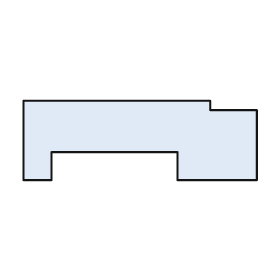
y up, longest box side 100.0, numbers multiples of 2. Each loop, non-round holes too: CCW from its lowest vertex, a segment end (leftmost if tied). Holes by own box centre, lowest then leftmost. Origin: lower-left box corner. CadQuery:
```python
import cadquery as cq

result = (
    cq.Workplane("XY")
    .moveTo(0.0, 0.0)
    .lineTo(12.0, 0.0)
    .lineTo(12.0, 12.0)
    .lineTo(66.0, 12.0)
    .lineTo(66.0, 0.0)
    .lineTo(100.0, 0.0)
    .lineTo(100.0, 30.0)
    .lineTo(80.0, 30.0)
    .lineTo(80.0, 34.0)
    .lineTo(0.0, 34.0)
    .close()
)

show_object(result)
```